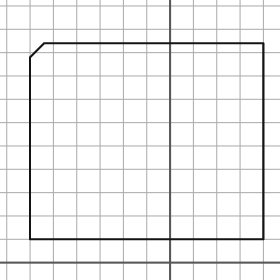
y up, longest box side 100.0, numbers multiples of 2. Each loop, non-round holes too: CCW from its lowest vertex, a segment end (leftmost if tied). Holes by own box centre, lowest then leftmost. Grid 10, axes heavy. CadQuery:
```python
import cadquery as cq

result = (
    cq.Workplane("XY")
    .moveTo(-60.0, 10.0)
    .lineTo(40.0, 10.0)
    .lineTo(40.0, 94.0)
    .lineTo(-54.0, 94.0)
    .lineTo(-60.0, 88.0)
    .close()
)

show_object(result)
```